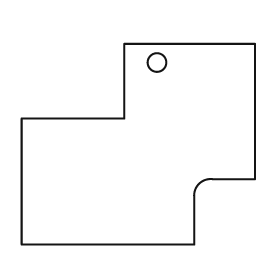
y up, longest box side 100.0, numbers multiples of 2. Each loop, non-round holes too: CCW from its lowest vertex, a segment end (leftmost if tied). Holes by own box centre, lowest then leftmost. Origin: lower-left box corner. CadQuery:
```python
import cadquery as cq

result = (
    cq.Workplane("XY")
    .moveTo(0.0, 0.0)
    .lineTo(74.0, 0.0)
    .lineTo(74.0, 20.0)
    .threePointArc((76.0, 26.0), (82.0, 28.0))
    .lineTo(100.0, 28.0)
    .lineTo(100.0, 86.0)
    .lineTo(44.0, 86.0)
    .lineTo(44.0, 54.0)
    .lineTo(0.0, 54.0)
    .close()
    .moveTo(58.0, 78.0)
    .circle(4.0)
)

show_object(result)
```